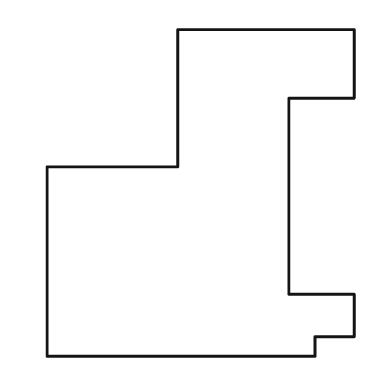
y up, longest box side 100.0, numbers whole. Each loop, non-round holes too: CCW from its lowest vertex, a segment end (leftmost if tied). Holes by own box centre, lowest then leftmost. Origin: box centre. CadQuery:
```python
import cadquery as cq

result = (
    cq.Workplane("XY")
    .moveTo(-47.0, -50.0)
    .lineTo(35.0, -50.0)
    .lineTo(35.0, -44.0)
    .lineTo(47.0, -44.0)
    .lineTo(47.0, -31.0)
    .lineTo(27.0, -31.0)
    .lineTo(27.0, 29.0)
    .lineTo(47.0, 29.0)
    .lineTo(47.0, 50.0)
    .lineTo(-7.0, 50.0)
    .lineTo(-7.0, 8.0)
    .lineTo(-47.0, 8.0)
    .close()
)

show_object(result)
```